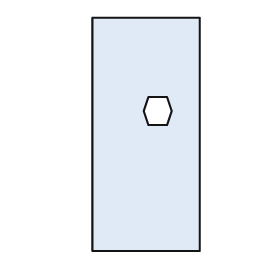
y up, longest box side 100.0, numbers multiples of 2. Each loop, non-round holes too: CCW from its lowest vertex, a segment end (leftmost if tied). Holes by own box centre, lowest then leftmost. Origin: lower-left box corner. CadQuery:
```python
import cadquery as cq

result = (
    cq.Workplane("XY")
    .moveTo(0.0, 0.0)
    .lineTo(46.0, 0.0)
    .lineTo(46.0, 100.0)
    .lineTo(0.0, 100.0)
    .close()
    .moveTo(24.0, 54.0)
    .lineTo(32.0, 54.0)
    .lineTo(34.0, 60.0)
    .lineTo(32.0, 66.0)
    .lineTo(24.0, 66.0)
    .lineTo(22.0, 60.0)
    .close()
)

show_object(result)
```